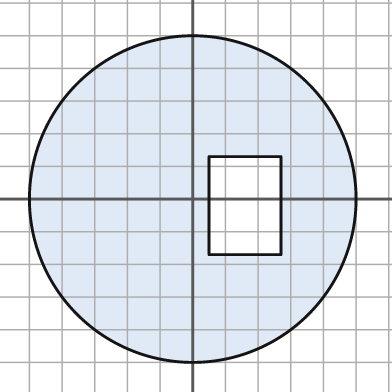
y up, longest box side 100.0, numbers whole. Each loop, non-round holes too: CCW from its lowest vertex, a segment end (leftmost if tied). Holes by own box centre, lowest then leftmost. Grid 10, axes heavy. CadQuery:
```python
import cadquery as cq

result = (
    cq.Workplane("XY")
    .moveTo(0.0, 0.0)
    .circle(50.0)
    .moveTo(5.0, -17.0)
    .lineTo(27.0, -17.0)
    .lineTo(27.0, 13.0)
    .lineTo(5.0, 13.0)
    .close()
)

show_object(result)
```